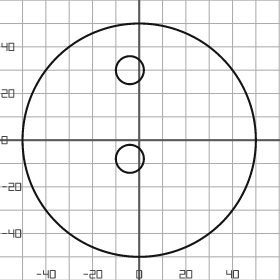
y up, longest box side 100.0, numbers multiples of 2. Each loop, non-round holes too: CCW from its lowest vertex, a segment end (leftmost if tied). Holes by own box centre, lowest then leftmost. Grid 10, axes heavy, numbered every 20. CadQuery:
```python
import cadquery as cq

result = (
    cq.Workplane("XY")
    .moveTo(0.0, 0.0)
    .circle(50.0)
    .moveTo(-4.0, -8.0)
    .circle(6.0)
    .moveTo(-4.0, 30.0)
    .circle(6.0)
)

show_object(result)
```